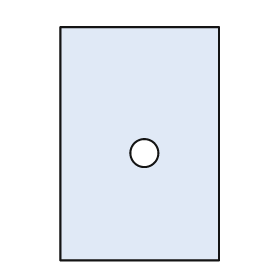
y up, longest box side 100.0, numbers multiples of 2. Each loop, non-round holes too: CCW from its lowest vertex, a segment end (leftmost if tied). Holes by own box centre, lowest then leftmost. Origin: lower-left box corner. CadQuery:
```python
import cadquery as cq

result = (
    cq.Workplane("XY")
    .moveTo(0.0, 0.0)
    .lineTo(68.0, 0.0)
    .lineTo(68.0, 100.0)
    .lineTo(0.0, 100.0)
    .close()
    .moveTo(36.0, 46.0)
    .circle(6.0)
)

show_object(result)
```